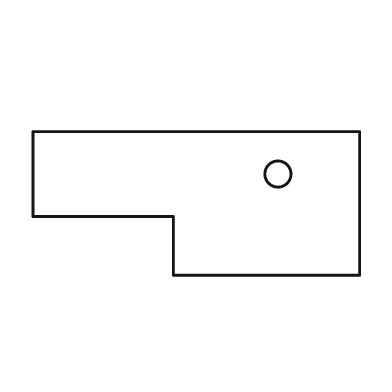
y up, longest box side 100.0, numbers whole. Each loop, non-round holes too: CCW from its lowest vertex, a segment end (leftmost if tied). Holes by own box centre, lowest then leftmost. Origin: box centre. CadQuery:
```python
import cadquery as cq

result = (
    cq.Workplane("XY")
    .moveTo(-7.0, -22.0)
    .lineTo(50.0, -22.0)
    .lineTo(50.0, 22.0)
    .lineTo(-50.0, 22.0)
    .lineTo(-50.0, -4.0)
    .lineTo(-7.0, -4.0)
    .close()
    .moveTo(25.0, 9.0)
    .circle(4.0)
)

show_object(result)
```